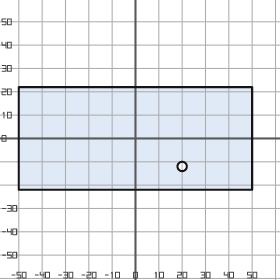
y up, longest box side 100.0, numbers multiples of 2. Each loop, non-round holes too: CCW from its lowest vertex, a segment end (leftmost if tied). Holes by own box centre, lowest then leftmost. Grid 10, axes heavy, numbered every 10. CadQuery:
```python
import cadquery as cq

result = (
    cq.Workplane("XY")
    .moveTo(-50.0, -22.0)
    .lineTo(50.0, -22.0)
    .lineTo(50.0, 22.0)
    .lineTo(-50.0, 22.0)
    .close()
    .moveTo(20.0, -12.0)
    .circle(2.0)
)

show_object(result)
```